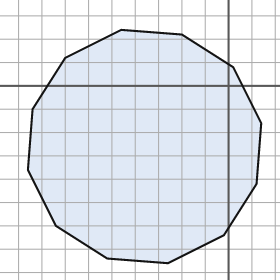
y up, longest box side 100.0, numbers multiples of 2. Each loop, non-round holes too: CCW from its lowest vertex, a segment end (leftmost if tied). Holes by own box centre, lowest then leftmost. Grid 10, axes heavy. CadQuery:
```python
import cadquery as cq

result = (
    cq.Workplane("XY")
    .moveTo(-26.0, -76.0)
    .lineTo(-2.0, -64.0)
    .lineTo(12.0, -42.0)
    .lineTo(14.0, -16.0)
    .lineTo(2.0, 8.0)
    .lineTo(-20.0, 22.0)
    .lineTo(-46.0, 24.0)
    .lineTo(-70.0, 12.0)
    .lineTo(-84.0, -10.0)
    .lineTo(-86.0, -36.0)
    .lineTo(-74.0, -60.0)
    .lineTo(-52.0, -74.0)
    .close()
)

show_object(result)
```